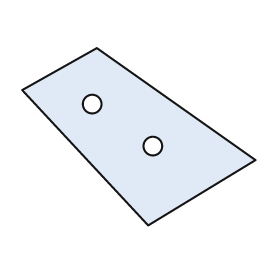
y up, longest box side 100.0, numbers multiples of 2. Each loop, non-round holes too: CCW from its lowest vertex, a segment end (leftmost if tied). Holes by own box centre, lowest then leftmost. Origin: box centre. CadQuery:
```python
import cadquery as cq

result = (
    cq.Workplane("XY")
    .moveTo(4.0, -38.0)
    .lineTo(50.0, -10.0)
    .lineTo(-18.0, 38.0)
    .lineTo(-50.0, 20.0)
    .close()
    .moveTo(6.0, -4.0)
    .circle(4.0)
    .moveTo(-20.0, 14.0)
    .circle(4.0)
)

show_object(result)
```